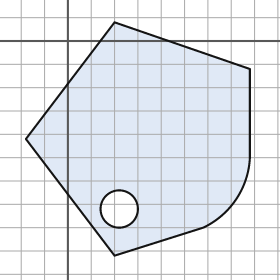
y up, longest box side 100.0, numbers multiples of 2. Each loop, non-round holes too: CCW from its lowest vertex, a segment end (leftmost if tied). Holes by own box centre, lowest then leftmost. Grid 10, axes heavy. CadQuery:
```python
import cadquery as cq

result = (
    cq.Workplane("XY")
    .moveTo(20.0, -92.0)
    .lineTo(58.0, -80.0)
    .threePointArc((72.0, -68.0), (78.0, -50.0))
    .lineTo(78.0, -12.0)
    .lineTo(20.0, 8.0)
    .lineTo(-18.0, -42.0)
    .close()
    .moveTo(22.0, -72.0)
    .circle(8.0)
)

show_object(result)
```